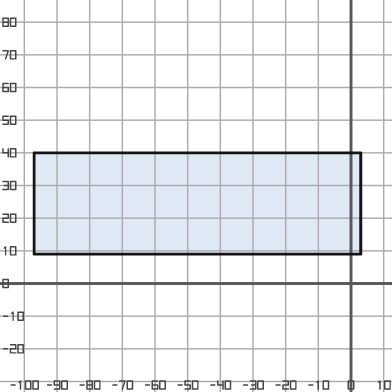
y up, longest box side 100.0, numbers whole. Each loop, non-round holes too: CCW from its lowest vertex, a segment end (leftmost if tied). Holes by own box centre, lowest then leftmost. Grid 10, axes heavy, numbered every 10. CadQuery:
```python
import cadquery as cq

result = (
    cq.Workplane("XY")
    .moveTo(-97.0, 9.0)
    .lineTo(3.0, 9.0)
    .lineTo(3.0, 40.0)
    .lineTo(-97.0, 40.0)
    .close()
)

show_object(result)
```